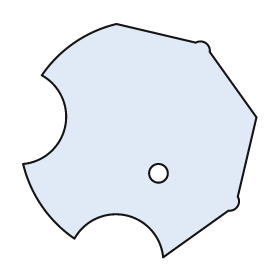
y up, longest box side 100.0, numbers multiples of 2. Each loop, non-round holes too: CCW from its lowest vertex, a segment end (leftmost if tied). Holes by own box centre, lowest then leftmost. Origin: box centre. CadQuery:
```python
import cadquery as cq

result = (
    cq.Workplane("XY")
    .moveTo(10.0, -50.0)
    .lineTo(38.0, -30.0)
    .threePointArc((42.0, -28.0), (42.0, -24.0))
    .lineTo(50.0, 10.0)
    .lineTo(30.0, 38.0)
    .threePointArc((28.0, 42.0), (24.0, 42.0))
    .lineTo(-10.0, 50.0)
    .threePointArc((-28.0, 42.0), (-42.0, 28.0))
    .threePointArc((-32.0, 6.0), (-50.0, -10.0))
    .threePointArc((-42.0, -28.0), (-28.0, -42.0))
    .threePointArc((-6.0, -32.0), (10.0, -50.0))
    .close()
    .moveTo(8.0, -14.0)
    .circle(4.0)
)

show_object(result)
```